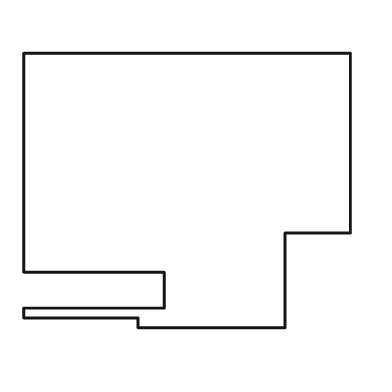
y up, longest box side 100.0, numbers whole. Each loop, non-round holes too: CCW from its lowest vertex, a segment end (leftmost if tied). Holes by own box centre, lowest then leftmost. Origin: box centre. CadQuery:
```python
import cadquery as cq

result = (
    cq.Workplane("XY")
    .moveTo(-15.0, -42.0)
    .lineTo(30.0, -42.0)
    .lineTo(30.0, -13.0)
    .lineTo(50.0, -13.0)
    .lineTo(50.0, 42.0)
    .lineTo(-50.0, 42.0)
    .lineTo(-50.0, -25.0)
    .lineTo(-7.0, -25.0)
    .lineTo(-7.0, -36.0)
    .lineTo(-50.0, -36.0)
    .lineTo(-50.0, -39.0)
    .lineTo(-15.0, -39.0)
    .close()
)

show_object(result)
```